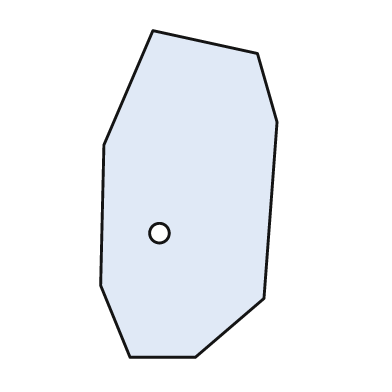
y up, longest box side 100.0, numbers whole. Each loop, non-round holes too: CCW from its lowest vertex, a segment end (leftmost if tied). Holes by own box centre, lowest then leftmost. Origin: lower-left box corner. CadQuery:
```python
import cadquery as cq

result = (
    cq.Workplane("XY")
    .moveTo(9.0, 0.0)
    .lineTo(29.0, 0.0)
    .lineTo(50.0, 18.0)
    .lineTo(54.0, 72.0)
    .lineTo(48.0, 93.0)
    .lineTo(16.0, 100.0)
    .lineTo(1.0, 65.0)
    .lineTo(0.0, 22.0)
    .close()
    .moveTo(18.0, 38.0)
    .circle(3.0)
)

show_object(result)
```